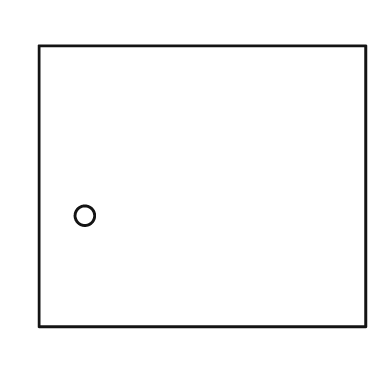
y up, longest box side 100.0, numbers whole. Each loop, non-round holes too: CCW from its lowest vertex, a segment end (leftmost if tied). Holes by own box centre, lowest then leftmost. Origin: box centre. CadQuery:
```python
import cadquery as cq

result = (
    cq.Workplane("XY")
    .moveTo(-50.0, -43.0)
    .lineTo(50.0, -43.0)
    .lineTo(50.0, 43.0)
    .lineTo(-50.0, 43.0)
    .close()
    .moveTo(-36.0, -9.0)
    .circle(3.0)
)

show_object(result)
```